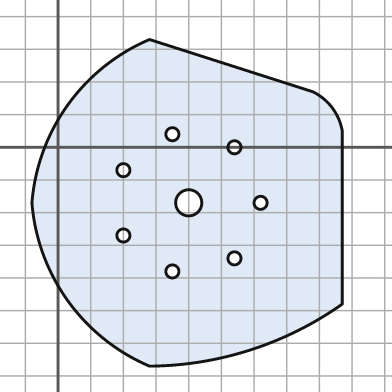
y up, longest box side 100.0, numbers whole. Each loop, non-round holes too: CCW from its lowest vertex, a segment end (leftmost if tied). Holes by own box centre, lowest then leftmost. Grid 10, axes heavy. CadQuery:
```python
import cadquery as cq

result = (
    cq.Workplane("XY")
    .moveTo(28.0, -67.0)
    .threePointArc((59.0, -62.0), (87.0, -48.0))
    .lineTo(87.0, 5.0)
    .threePointArc((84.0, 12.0), (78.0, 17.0))
    .lineTo(28.0, 33.0)
    .threePointArc((3.0, 13.0), (-8.0, -17.0))
    .threePointArc((3.0, -47.0), (28.0, -67.0))
    .close()
    .moveTo(35.0, -38.0)
    .circle(2.0)
    .moveTo(54.0, -34.0)
    .circle(2.0)
    .moveTo(20.0, -27.0)
    .circle(2.0)
    .moveTo(40.0, -17.0)
    .circle(4.0)
    .moveTo(62.0, -17.0)
    .circle(2.0)
    .moveTo(20.0, -7.0)
    .circle(2.0)
    .moveTo(54.0, 0.0)
    .circle(2.0)
    .moveTo(35.0, 4.0)
    .circle(2.0)
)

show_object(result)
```